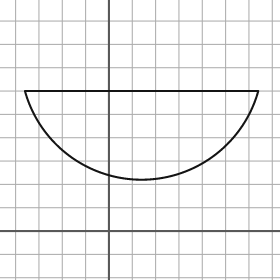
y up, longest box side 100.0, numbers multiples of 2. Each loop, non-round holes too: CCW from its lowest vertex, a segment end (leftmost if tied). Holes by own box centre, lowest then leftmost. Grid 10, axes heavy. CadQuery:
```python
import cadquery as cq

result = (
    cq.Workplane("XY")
    .moveTo(-36.0, 60.0)
    .threePointArc((14.0, 22.0), (64.0, 60.0))
    .close()
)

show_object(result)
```